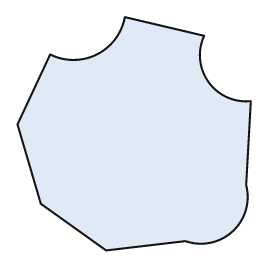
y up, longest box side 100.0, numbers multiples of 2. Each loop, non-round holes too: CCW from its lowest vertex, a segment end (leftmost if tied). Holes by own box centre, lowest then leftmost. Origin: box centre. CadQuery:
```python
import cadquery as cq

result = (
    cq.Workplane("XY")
    .moveTo(-12.0, -50.0)
    .lineTo(22.0, -46.0)
    .threePointArc((42.0, -42.0), (48.0, -22.0))
    .lineTo(50.0, 14.0)
    .threePointArc((32.0, 22.0), (30.0, 42.0))
    .lineTo(-4.0, 50.0)
    .threePointArc((-16.0, 34.0), (-36.0, 34.0))
    .lineTo(-50.0, 4.0)
    .lineTo(-40.0, -30.0)
    .close()
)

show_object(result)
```